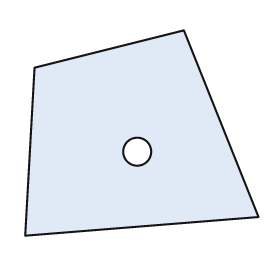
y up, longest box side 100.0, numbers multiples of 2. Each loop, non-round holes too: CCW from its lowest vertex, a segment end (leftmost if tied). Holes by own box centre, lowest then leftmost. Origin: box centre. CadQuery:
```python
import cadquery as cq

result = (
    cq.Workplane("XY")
    .moveTo(-50.0, -44.0)
    .lineTo(50.0, -36.0)
    .lineTo(18.0, 44.0)
    .lineTo(-46.0, 28.0)
    .close()
    .moveTo(-2.0, -8.0)
    .circle(6.0)
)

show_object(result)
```